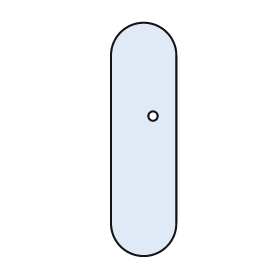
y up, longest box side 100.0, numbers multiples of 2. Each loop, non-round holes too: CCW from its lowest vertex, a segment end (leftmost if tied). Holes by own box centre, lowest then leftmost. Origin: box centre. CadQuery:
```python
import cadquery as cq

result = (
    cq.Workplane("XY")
    .moveTo(-14.0, -36.0)
    .threePointArc((0.0, -50.0), (14.0, -36.0))
    .lineTo(14.0, 36.0)
    .threePointArc((0.0, 50.0), (-14.0, 36.0))
    .close()
    .moveTo(4.0, 10.0)
    .circle(2.0)
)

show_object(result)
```